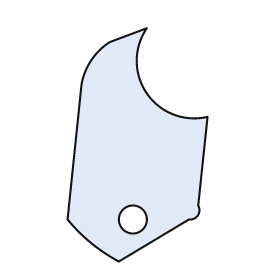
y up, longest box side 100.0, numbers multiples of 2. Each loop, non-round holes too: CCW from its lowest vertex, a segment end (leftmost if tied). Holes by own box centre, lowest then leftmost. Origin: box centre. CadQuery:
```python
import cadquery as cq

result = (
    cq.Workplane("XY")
    .moveTo(-8.0, -50.0)
    .lineTo(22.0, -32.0)
    .threePointArc((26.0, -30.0), (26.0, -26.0))
    .lineTo(30.0, 12.0)
    .threePointArc((4.0, 22.0), (4.0, 50.0))
    .lineTo(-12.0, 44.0)
    .threePointArc((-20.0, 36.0), (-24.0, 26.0))
    .lineTo(-30.0, -32.0)
    .threePointArc((-20.0, -42.0), (-8.0, -50.0))
    .close()
    .moveTo(-2.0, -32.0)
    .circle(6.0)
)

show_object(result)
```